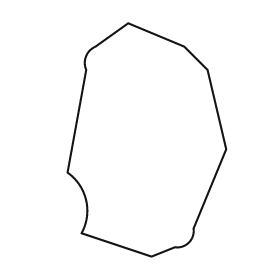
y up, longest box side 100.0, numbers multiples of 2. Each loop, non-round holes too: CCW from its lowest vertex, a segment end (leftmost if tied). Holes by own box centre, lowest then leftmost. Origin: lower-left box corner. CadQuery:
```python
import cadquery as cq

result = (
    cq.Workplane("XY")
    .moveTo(36.0, 0.0)
    .lineTo(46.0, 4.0)
    .threePointArc((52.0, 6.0), (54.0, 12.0))
    .lineTo(68.0, 46.0)
    .lineTo(60.0, 80.0)
    .lineTo(50.0, 90.0)
    .lineTo(26.0, 100.0)
    .lineTo(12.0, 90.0)
    .threePointArc((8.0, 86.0), (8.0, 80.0))
    .lineTo(0.0, 36.0)
    .threePointArc((8.0, 24.0), (6.0, 10.0))
    .close()
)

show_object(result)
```